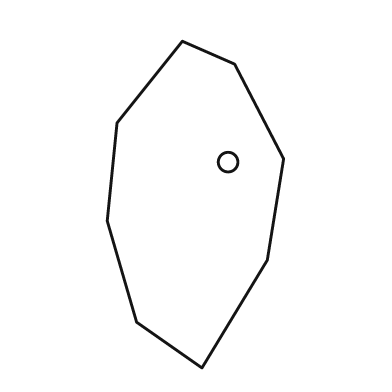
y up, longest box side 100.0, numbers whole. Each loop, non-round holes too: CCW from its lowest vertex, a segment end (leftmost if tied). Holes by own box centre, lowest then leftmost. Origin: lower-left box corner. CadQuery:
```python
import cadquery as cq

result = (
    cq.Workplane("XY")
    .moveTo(29.0, 0.0)
    .lineTo(49.0, 33.0)
    .lineTo(54.0, 64.0)
    .lineTo(39.0, 93.0)
    .lineTo(23.0, 100.0)
    .lineTo(3.0, 75.0)
    .lineTo(0.0, 45.0)
    .lineTo(9.0, 14.0)
    .close()
    .moveTo(37.0, 63.0)
    .circle(3.0)
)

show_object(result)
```